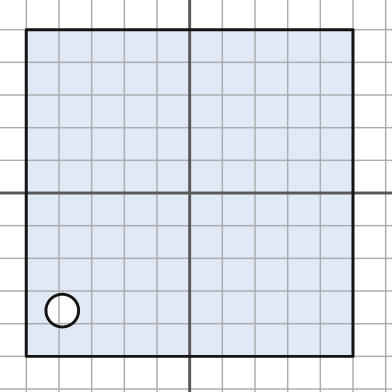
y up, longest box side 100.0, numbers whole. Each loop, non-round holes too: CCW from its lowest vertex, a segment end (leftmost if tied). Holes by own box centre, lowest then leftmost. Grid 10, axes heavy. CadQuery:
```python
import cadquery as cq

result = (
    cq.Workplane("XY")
    .moveTo(-50.0, -50.0)
    .lineTo(50.0, -50.0)
    .lineTo(50.0, 50.0)
    .lineTo(-50.0, 50.0)
    .close()
    .moveTo(-39.0, -36.0)
    .circle(5.0)
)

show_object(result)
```